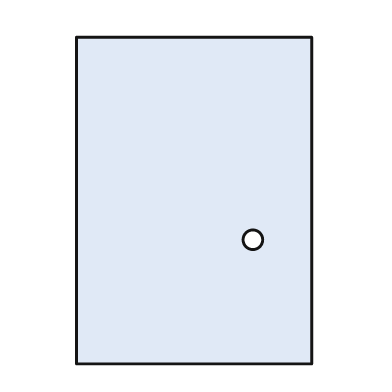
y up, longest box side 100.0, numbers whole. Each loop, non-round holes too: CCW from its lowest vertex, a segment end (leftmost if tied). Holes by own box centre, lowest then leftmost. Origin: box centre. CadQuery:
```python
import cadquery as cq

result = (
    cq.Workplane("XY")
    .moveTo(-36.0, -50.0)
    .lineTo(36.0, -50.0)
    .lineTo(36.0, 50.0)
    .lineTo(-36.0, 50.0)
    .close()
    .moveTo(18.0, -12.0)
    .circle(3.0)
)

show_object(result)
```